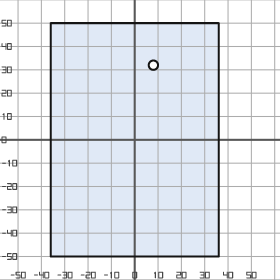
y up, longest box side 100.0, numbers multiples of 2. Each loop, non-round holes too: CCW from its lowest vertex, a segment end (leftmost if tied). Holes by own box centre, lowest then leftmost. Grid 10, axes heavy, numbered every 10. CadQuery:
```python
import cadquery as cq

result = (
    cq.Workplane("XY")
    .moveTo(-36.0, -50.0)
    .lineTo(36.0, -50.0)
    .lineTo(36.0, 50.0)
    .lineTo(-36.0, 50.0)
    .close()
    .moveTo(8.0, 32.0)
    .circle(2.0)
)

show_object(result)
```